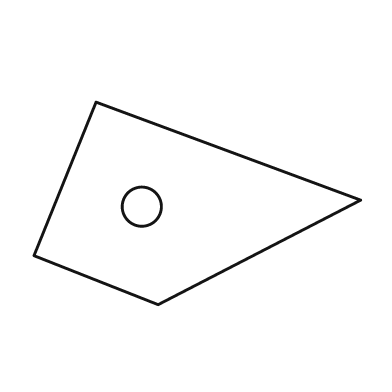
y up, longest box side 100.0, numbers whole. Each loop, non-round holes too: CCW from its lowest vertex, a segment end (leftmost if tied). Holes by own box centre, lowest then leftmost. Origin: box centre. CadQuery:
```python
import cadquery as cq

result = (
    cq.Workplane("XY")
    .moveTo(-12.0, -31.0)
    .lineTo(50.0, 1.0)
    .lineTo(-31.0, 31.0)
    .lineTo(-50.0, -16.0)
    .close()
    .moveTo(-17.0, -1.0)
    .circle(6.0)
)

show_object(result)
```